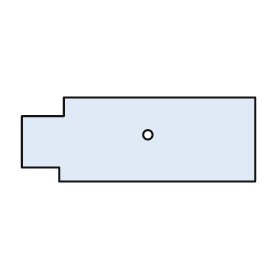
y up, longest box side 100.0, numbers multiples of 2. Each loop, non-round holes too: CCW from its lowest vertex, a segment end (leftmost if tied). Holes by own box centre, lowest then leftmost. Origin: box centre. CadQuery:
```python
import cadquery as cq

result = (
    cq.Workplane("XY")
    .moveTo(-34.0, -18.0)
    .lineTo(50.0, -18.0)
    .lineTo(50.0, 18.0)
    .lineTo(-32.0, 18.0)
    .lineTo(-32.0, 10.0)
    .lineTo(-50.0, 10.0)
    .lineTo(-50.0, -12.0)
    .lineTo(-34.0, -12.0)
    .close()
    .moveTo(4.0, 2.0)
    .circle(2.0)
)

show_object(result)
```